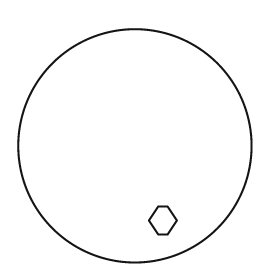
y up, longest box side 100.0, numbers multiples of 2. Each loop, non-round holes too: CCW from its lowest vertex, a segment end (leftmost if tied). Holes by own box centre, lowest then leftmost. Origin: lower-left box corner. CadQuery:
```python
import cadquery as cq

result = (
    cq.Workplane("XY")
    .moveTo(50.0, 50.0)
    .circle(50.0)
    .moveTo(60.0, 12.0)
    .lineTo(64.0, 12.0)
    .lineTo(68.0, 18.0)
    .lineTo(64.0, 24.0)
    .lineTo(60.0, 24.0)
    .lineTo(56.0, 18.0)
    .close()
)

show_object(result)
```